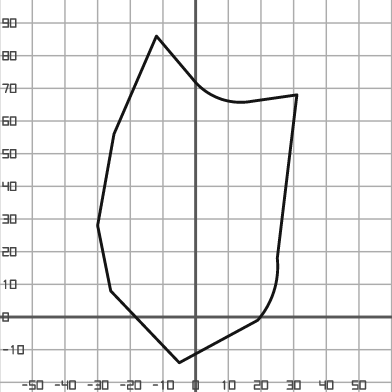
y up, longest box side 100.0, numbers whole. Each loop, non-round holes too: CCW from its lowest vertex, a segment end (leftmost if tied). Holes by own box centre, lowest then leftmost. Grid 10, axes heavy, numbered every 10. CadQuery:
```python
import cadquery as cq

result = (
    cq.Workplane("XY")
    .moveTo(-5.0, -14.0)
    .lineTo(19.0, -1.0)
    .threePointArc((24.0, 8.0), (25.0, 18.0))
    .lineTo(31.0, 68.0)
    .lineTo(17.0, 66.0)
    .threePointArc((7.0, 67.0), (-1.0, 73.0))
    .lineTo(-12.0, 86.0)
    .lineTo(-25.0, 56.0)
    .lineTo(-30.0, 28.0)
    .lineTo(-26.0, 8.0)
    .close()
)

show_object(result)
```